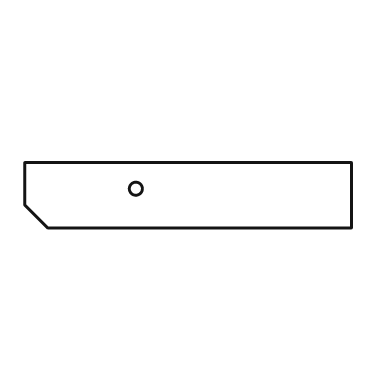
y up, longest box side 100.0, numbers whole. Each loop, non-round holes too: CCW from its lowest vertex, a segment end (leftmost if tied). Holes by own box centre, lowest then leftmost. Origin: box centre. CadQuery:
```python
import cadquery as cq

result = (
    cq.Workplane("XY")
    .moveTo(-43.0, -10.0)
    .lineTo(50.0, -10.0)
    .lineTo(50.0, 10.0)
    .lineTo(-50.0, 10.0)
    .lineTo(-50.0, -3.0)
    .close()
    .moveTo(-16.0, 2.0)
    .circle(2.0)
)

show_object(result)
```